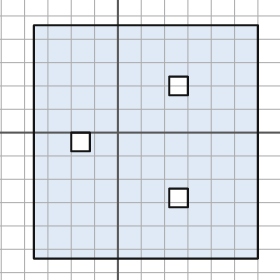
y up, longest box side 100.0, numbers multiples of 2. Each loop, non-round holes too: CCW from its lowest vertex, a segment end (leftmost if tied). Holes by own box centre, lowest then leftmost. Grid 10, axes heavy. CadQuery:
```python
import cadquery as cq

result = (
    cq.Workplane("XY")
    .moveTo(-36.0, -54.0)
    .lineTo(60.0, -54.0)
    .lineTo(60.0, 46.0)
    .lineTo(-36.0, 46.0)
    .close()
    .moveTo(22.0, -32.0)
    .lineTo(30.0, -32.0)
    .lineTo(30.0, -24.0)
    .lineTo(22.0, -24.0)
    .close()
    .moveTo(-20.0, -8.0)
    .lineTo(-12.0, -8.0)
    .lineTo(-12.0, 0.0)
    .lineTo(-20.0, 0.0)
    .close()
    .moveTo(22.0, 16.0)
    .lineTo(30.0, 16.0)
    .lineTo(30.0, 24.0)
    .lineTo(22.0, 24.0)
    .close()
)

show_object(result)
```